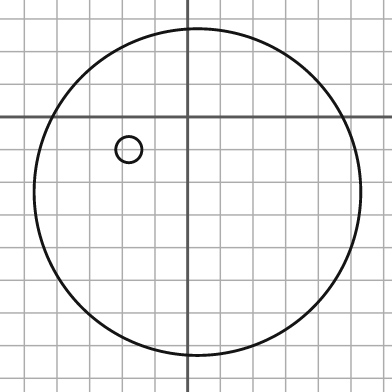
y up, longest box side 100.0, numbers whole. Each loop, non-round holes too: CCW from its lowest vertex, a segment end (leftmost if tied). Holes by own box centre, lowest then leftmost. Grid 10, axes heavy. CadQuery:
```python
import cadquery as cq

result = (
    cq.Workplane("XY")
    .moveTo(3.0, -23.0)
    .circle(50.0)
    .moveTo(-18.0, -10.0)
    .circle(4.0)
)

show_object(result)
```